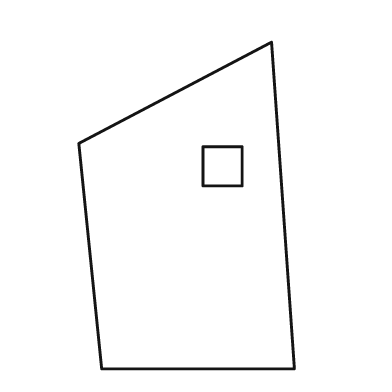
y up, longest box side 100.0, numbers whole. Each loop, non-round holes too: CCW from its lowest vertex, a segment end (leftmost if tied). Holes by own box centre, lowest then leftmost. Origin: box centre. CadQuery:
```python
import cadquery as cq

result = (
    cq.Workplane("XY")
    .moveTo(-26.0, -50.0)
    .lineTo(33.0, -50.0)
    .lineTo(26.0, 50.0)
    .lineTo(-33.0, 19.0)
    .close()
    .moveTo(5.0, 6.0)
    .lineTo(17.0, 6.0)
    .lineTo(17.0, 18.0)
    .lineTo(5.0, 18.0)
    .close()
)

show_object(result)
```